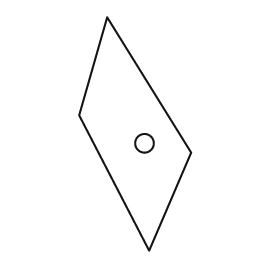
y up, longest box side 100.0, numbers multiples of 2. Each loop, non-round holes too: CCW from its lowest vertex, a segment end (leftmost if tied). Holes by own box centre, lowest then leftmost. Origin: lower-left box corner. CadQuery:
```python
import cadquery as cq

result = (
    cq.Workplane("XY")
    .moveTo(30.0, 0.0)
    .lineTo(48.0, 42.0)
    .lineTo(12.0, 100.0)
    .lineTo(0.0, 58.0)
    .close()
    .moveTo(28.0, 46.0)
    .circle(4.0)
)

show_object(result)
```